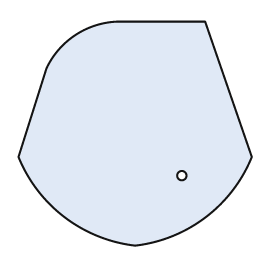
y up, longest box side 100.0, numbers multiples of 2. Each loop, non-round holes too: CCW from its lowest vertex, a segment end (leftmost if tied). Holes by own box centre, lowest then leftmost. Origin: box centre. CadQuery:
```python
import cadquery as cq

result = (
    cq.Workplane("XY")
    .moveTo(0.0, -48.0)
    .threePointArc((30.0, -36.0), (50.0, -10.0))
    .lineTo(30.0, 48.0)
    .lineTo(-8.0, 48.0)
    .threePointArc((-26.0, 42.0), (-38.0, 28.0))
    .lineTo(-50.0, -10.0)
    .threePointArc((-30.0, -36.0), (0.0, -48.0))
    .close()
    .moveTo(20.0, -18.0)
    .circle(2.0)
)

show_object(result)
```